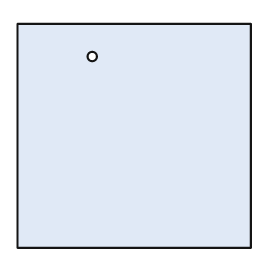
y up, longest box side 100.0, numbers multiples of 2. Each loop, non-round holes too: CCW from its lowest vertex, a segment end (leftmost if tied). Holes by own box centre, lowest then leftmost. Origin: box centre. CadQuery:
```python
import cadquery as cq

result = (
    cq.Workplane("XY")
    .moveTo(-50.0, -48.0)
    .lineTo(50.0, -48.0)
    .lineTo(50.0, 48.0)
    .lineTo(-50.0, 48.0)
    .close()
    .moveTo(-18.0, 34.0)
    .circle(2.0)
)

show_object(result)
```